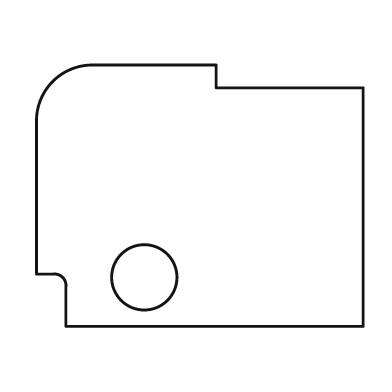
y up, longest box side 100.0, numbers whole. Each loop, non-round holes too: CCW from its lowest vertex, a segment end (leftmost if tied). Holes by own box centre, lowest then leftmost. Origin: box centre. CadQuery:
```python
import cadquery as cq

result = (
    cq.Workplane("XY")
    .moveTo(-41.0, -40.0)
    .lineTo(50.0, -40.0)
    .lineTo(50.0, 33.0)
    .lineTo(5.0, 33.0)
    .lineTo(5.0, 40.0)
    .lineTo(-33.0, 40.0)
    .threePointArc((-45.0, 35.0), (-50.0, 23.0))
    .lineTo(-50.0, -24.0)
    .lineTo(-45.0, -24.0)
    .threePointArc((-42.0, -25.0), (-41.0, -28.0))
    .close()
    .moveTo(-17.0, -25.0)
    .circle(10.0)
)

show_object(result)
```